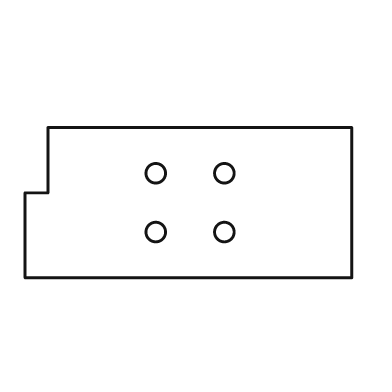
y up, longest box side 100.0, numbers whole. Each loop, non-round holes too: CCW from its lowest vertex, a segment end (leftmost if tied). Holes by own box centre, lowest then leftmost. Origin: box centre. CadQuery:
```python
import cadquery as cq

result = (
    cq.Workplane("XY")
    .moveTo(-50.0, -23.0)
    .lineTo(50.0, -23.0)
    .lineTo(50.0, 23.0)
    .lineTo(-43.0, 23.0)
    .lineTo(-43.0, 3.0)
    .lineTo(-50.0, 3.0)
    .close()
    .moveTo(-10.0, -9.0)
    .circle(3.0)
    .moveTo(11.0, -9.0)
    .circle(3.0)
    .moveTo(-10.0, 9.0)
    .circle(3.0)
    .moveTo(11.0, 9.0)
    .circle(3.0)
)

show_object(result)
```